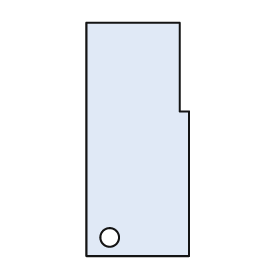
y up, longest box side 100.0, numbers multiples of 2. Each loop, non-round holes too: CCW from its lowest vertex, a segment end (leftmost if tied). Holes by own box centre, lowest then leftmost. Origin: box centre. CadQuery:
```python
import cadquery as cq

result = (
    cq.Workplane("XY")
    .moveTo(-22.0, -50.0)
    .lineTo(22.0, -50.0)
    .lineTo(22.0, 12.0)
    .lineTo(18.0, 12.0)
    .lineTo(18.0, 50.0)
    .lineTo(-22.0, 50.0)
    .close()
    .moveTo(-12.0, -42.0)
    .circle(4.0)
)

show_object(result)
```